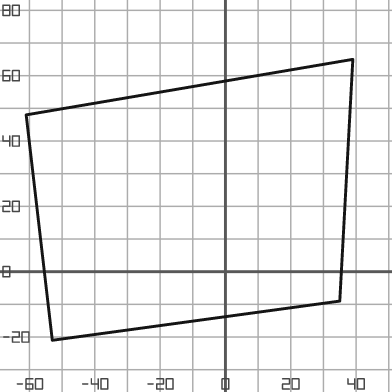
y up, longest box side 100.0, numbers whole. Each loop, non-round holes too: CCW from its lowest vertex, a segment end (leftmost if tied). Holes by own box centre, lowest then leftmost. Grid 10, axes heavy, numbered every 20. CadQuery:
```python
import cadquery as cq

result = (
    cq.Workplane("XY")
    .moveTo(-53.0, -21.0)
    .lineTo(35.0, -9.0)
    .lineTo(39.0, 65.0)
    .lineTo(-61.0, 48.0)
    .close()
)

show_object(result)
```